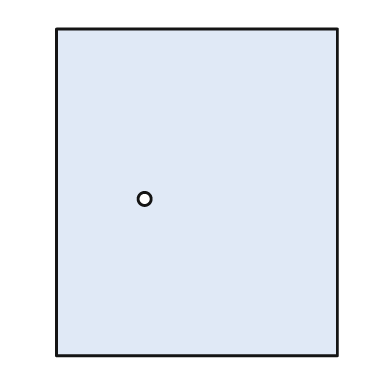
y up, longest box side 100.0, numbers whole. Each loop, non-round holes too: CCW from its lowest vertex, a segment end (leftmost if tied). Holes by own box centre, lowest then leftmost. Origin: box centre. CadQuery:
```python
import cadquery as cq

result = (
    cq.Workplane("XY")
    .moveTo(-43.0, -50.0)
    .lineTo(43.0, -50.0)
    .lineTo(43.0, 50.0)
    .lineTo(-43.0, 50.0)
    .close()
    .moveTo(-16.0, -2.0)
    .circle(2.0)
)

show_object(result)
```